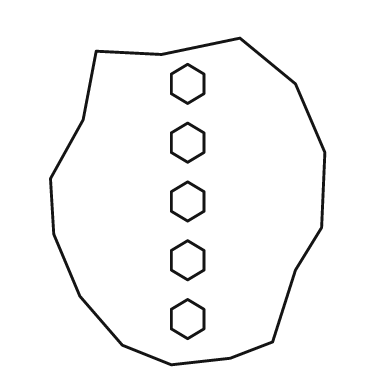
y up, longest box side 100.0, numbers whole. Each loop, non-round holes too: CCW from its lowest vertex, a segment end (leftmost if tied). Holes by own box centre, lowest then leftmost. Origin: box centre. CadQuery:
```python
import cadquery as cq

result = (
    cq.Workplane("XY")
    .moveTo(-5.0, -50.0)
    .lineTo(13.0, -48.0)
    .lineTo(26.0, -43.0)
    .lineTo(33.0, -21.0)
    .lineTo(41.0, -8.0)
    .lineTo(42.0, 15.0)
    .lineTo(33.0, 36.0)
    .lineTo(16.0, 50.0)
    .lineTo(-8.0, 45.0)
    .lineTo(-28.0, 46.0)
    .lineTo(-32.0, 25.0)
    .lineTo(-42.0, 7.0)
    .lineTo(-41.0, -10.0)
    .lineTo(-33.0, -29.0)
    .lineTo(-20.0, -44.0)
    .close()
    .moveTo(0.0, -42.0)
    .lineTo(5.0, -39.0)
    .lineTo(5.0, -33.0)
    .lineTo(0.0, -30.0)
    .lineTo(-5.0, -33.0)
    .lineTo(-5.0, -39.0)
    .close()
    .moveTo(0.0, -24.0)
    .lineTo(5.0, -21.0)
    .lineTo(5.0, -15.0)
    .lineTo(0.0, -12.0)
    .lineTo(-5.0, -15.0)
    .lineTo(-5.0, -21.0)
    .close()
    .moveTo(0.0, -6.0)
    .lineTo(5.0, -3.0)
    .lineTo(5.0, 3.0)
    .lineTo(0.0, 6.0)
    .lineTo(-5.0, 3.0)
    .lineTo(-5.0, -3.0)
    .close()
    .moveTo(0.0, 12.0)
    .lineTo(5.0, 15.0)
    .lineTo(5.0, 21.0)
    .lineTo(0.0, 24.0)
    .lineTo(-5.0, 21.0)
    .lineTo(-5.0, 15.0)
    .close()
    .moveTo(0.0, 30.0)
    .lineTo(5.0, 33.0)
    .lineTo(5.0, 39.0)
    .lineTo(0.0, 42.0)
    .lineTo(-5.0, 39.0)
    .lineTo(-5.0, 33.0)
    .close()
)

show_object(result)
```